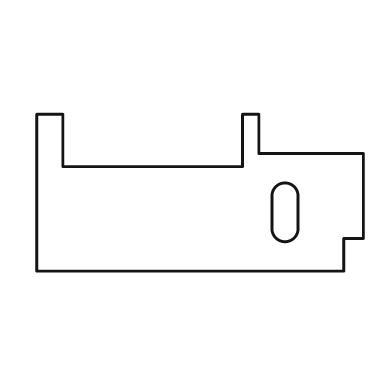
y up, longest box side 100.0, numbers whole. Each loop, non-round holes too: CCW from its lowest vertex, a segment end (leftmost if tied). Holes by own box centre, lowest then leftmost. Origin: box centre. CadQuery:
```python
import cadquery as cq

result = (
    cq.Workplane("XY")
    .moveTo(-50.0, -24.0)
    .lineTo(44.0, -24.0)
    .lineTo(44.0, -14.0)
    .lineTo(50.0, -14.0)
    .lineTo(50.0, 12.0)
    .lineTo(18.0, 12.0)
    .lineTo(18.0, 24.0)
    .lineTo(13.0, 24.0)
    .lineTo(13.0, 8.0)
    .lineTo(-42.0, 8.0)
    .lineTo(-42.0, 24.0)
    .lineTo(-50.0, 24.0)
    .close()
    .moveTo(22.0, -11.0)
    .threePointArc((26.0, -15.0), (30.0, -11.0))
    .lineTo(30.0, -1.0)
    .threePointArc((26.0, 3.0), (22.0, -1.0))
    .close()
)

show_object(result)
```